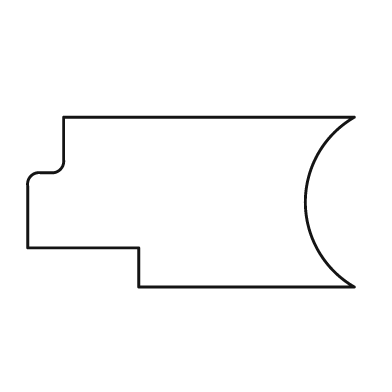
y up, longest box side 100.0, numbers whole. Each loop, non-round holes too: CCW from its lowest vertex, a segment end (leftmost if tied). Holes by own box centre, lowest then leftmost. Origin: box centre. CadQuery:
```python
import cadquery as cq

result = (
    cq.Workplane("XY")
    .moveTo(-16.0, -26.0)
    .lineTo(50.0, -26.0)
    .threePointArc((35.0, 0.0), (50.0, 26.0))
    .lineTo(-39.0, 26.0)
    .lineTo(-39.0, 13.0)
    .threePointArc((-40.0, 10.0), (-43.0, 9.0))
    .lineTo(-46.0, 9.0)
    .threePointArc((-49.0, 8.0), (-50.0, 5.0))
    .lineTo(-50.0, -14.0)
    .lineTo(-16.0, -14.0)
    .close()
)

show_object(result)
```